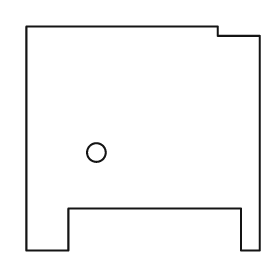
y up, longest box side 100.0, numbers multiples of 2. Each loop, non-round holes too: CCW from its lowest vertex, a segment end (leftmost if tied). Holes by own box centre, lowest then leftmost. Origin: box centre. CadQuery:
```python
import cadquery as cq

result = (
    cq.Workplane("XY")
    .moveTo(-50.0, -48.0)
    .lineTo(-32.0, -48.0)
    .lineTo(-32.0, -30.0)
    .lineTo(42.0, -30.0)
    .lineTo(42.0, -48.0)
    .lineTo(50.0, -48.0)
    .lineTo(50.0, 44.0)
    .lineTo(32.0, 44.0)
    .lineTo(32.0, 48.0)
    .lineTo(-50.0, 48.0)
    .close()
    .moveTo(-20.0, -6.0)
    .circle(4.0)
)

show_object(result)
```